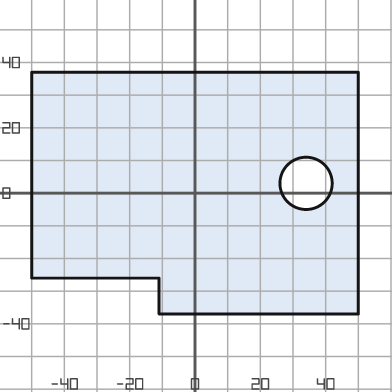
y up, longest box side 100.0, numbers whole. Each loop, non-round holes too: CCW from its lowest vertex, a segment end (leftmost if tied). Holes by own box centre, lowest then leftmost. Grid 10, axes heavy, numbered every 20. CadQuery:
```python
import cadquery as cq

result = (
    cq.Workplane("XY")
    .moveTo(-11.0, -37.0)
    .lineTo(50.0, -37.0)
    .lineTo(50.0, 37.0)
    .lineTo(-50.0, 37.0)
    .lineTo(-50.0, -26.0)
    .lineTo(-11.0, -26.0)
    .close()
    .moveTo(34.0, 3.0)
    .circle(8.0)
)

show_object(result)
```